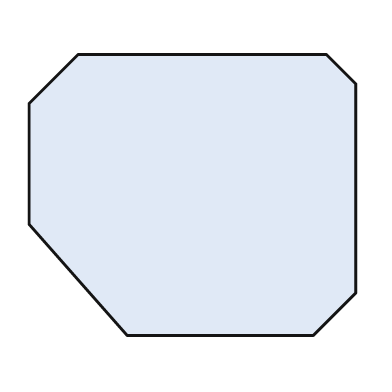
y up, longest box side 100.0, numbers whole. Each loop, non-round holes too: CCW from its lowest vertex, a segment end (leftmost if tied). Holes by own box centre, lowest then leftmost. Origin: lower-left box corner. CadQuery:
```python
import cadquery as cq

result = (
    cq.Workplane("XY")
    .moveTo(30.0, 0.0)
    .lineTo(87.0, 0.0)
    .lineTo(100.0, 13.0)
    .lineTo(100.0, 77.0)
    .lineTo(91.0, 86.0)
    .lineTo(15.0, 86.0)
    .lineTo(0.0, 71.0)
    .lineTo(0.0, 34.0)
    .close()
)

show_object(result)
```